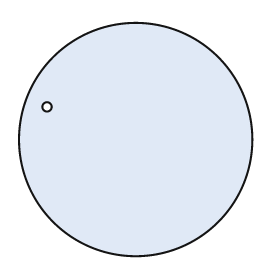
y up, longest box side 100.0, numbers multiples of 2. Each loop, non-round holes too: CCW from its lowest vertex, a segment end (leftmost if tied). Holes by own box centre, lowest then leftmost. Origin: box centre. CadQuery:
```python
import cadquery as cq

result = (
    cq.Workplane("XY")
    .moveTo(0.0, 0.0)
    .circle(50.0)
    .moveTo(-38.0, 14.0)
    .circle(2.0)
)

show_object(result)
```